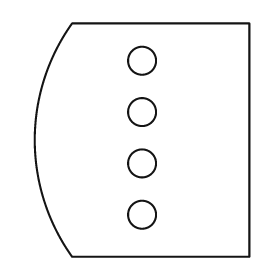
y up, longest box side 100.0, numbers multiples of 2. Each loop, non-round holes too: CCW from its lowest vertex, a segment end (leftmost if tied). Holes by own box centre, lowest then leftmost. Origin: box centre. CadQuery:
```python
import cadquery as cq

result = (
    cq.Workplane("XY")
    .moveTo(-30.0, -50.0)
    .lineTo(46.0, -50.0)
    .lineTo(46.0, 50.0)
    .lineTo(-30.0, 50.0)
    .threePointArc((-46.0, 0.0), (-30.0, -50.0))
    .close()
    .moveTo(0.0, -32.0)
    .circle(6.0)
    .moveTo(0.0, -10.0)
    .circle(6.0)
    .moveTo(0.0, 12.0)
    .circle(6.0)
    .moveTo(0.0, 34.0)
    .circle(6.0)
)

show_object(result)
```